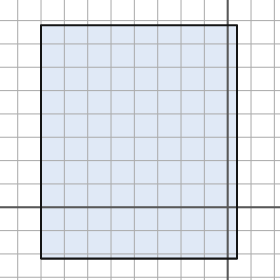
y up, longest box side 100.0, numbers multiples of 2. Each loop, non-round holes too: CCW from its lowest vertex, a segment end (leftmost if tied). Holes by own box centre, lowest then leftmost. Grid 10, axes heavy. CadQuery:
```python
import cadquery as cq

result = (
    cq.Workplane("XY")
    .moveTo(-80.0, -22.0)
    .lineTo(4.0, -22.0)
    .lineTo(4.0, 78.0)
    .lineTo(-80.0, 78.0)
    .close()
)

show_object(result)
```